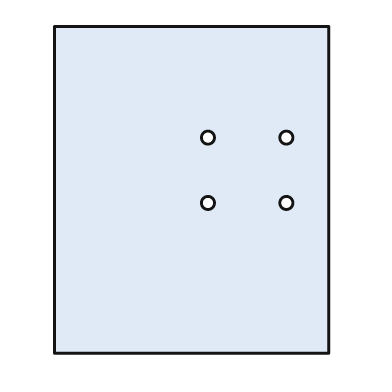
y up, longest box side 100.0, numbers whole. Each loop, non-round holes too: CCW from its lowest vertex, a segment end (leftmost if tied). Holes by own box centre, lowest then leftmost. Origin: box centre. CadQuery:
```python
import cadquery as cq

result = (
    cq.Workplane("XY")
    .moveTo(-42.0, -50.0)
    .lineTo(42.0, -50.0)
    .lineTo(42.0, 50.0)
    .lineTo(-42.0, 50.0)
    .close()
    .moveTo(5.0, -4.0)
    .circle(2.0)
    .moveTo(29.0, -4.0)
    .circle(2.0)
    .moveTo(5.0, 16.0)
    .circle(2.0)
    .moveTo(29.0, 16.0)
    .circle(2.0)
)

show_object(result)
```